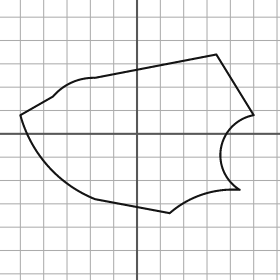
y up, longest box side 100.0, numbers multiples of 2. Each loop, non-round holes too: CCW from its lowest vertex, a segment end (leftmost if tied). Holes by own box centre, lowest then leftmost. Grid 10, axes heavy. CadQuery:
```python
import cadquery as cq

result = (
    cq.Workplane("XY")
    .moveTo(14.0, -34.0)
    .threePointArc((28.0, -26.0), (44.0, -24.0))
    .threePointArc((36.0, -6.0), (50.0, 8.0))
    .lineTo(34.0, 34.0)
    .lineTo(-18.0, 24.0)
    .threePointArc((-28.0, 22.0), (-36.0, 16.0))
    .lineTo(-50.0, 8.0)
    .threePointArc((-38.0, -14.0), (-18.0, -28.0))
    .close()
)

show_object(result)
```